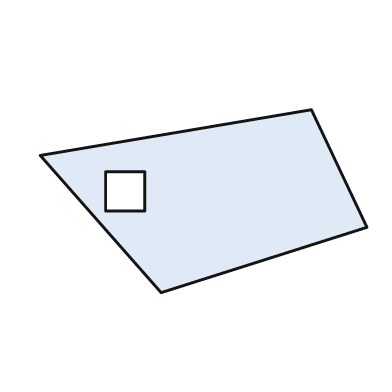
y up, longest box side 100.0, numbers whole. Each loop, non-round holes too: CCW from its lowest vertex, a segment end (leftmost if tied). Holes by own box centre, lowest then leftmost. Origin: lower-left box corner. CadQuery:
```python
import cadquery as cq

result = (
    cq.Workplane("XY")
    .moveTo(37.0, 0.0)
    .lineTo(100.0, 20.0)
    .lineTo(83.0, 56.0)
    .lineTo(0.0, 42.0)
    .close()
    .moveTo(20.0, 25.0)
    .lineTo(32.0, 25.0)
    .lineTo(32.0, 37.0)
    .lineTo(20.0, 37.0)
    .close()
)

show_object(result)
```